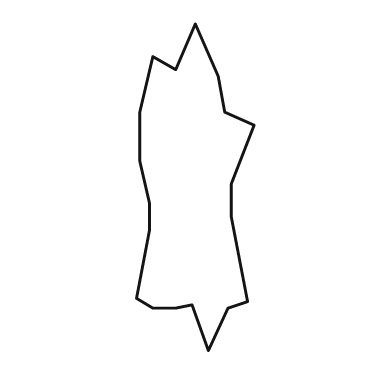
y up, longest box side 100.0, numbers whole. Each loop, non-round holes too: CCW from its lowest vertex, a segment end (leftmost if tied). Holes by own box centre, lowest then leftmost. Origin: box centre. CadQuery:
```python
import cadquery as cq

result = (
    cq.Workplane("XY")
    .moveTo(4.0, -50.0)
    .lineTo(10.0, -37.0)
    .lineTo(16.0, -35.0)
    .lineTo(11.0, -9.0)
    .lineTo(11.0, 1.0)
    .lineTo(18.0, 19.0)
    .lineTo(9.0, 23.0)
    .lineTo(7.0, 34.0)
    .lineTo(0.0, 50.0)
    .lineTo(-6.0, 36.0)
    .lineTo(-13.0, 40.0)
    .lineTo(-17.0, 23.0)
    .lineTo(-17.0, 8.0)
    .lineTo(-14.0, -5.0)
    .lineTo(-14.0, -13.0)
    .lineTo(-18.0, -34.0)
    .lineTo(-13.0, -37.0)
    .lineTo(-6.0, -37.0)
    .lineTo(-1.0, -36.0)
    .close()
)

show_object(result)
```